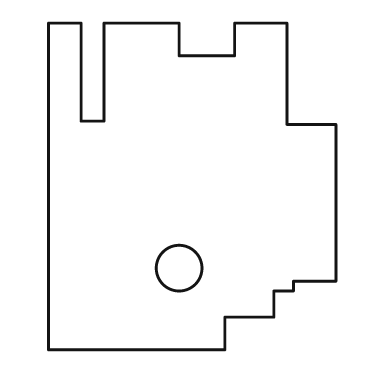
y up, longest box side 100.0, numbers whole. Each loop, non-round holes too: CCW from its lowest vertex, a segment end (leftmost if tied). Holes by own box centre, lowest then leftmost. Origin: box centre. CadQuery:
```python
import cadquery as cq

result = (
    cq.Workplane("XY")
    .moveTo(-44.0, -50.0)
    .lineTo(10.0, -50.0)
    .lineTo(10.0, -40.0)
    .lineTo(25.0, -40.0)
    .lineTo(25.0, -32.0)
    .lineTo(31.0, -32.0)
    .lineTo(31.0, -29.0)
    .lineTo(44.0, -29.0)
    .lineTo(44.0, 19.0)
    .lineTo(29.0, 19.0)
    .lineTo(29.0, 50.0)
    .lineTo(13.0, 50.0)
    .lineTo(13.0, 40.0)
    .lineTo(-4.0, 40.0)
    .lineTo(-4.0, 50.0)
    .lineTo(-27.0, 50.0)
    .lineTo(-27.0, 20.0)
    .lineTo(-34.0, 20.0)
    .lineTo(-34.0, 50.0)
    .lineTo(-44.0, 50.0)
    .close()
    .moveTo(-4.0, -25.0)
    .circle(7.0)
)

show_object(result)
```